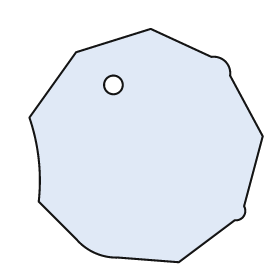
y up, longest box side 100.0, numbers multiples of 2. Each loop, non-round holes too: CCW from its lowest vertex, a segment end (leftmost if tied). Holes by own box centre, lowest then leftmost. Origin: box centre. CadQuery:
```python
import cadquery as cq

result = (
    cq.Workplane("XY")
    .moveTo(14.0, -50.0)
    .lineTo(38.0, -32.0)
    .threePointArc((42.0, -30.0), (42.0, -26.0))
    .lineTo(50.0, 4.0)
    .lineTo(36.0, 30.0)
    .threePointArc((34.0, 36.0), (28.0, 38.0))
    .lineTo(2.0, 50.0)
    .lineTo(-30.0, 40.0)
    .lineTo(-50.0, 12.0)
    .threePointArc((-46.0, -6.0), (-46.0, -24.0))
    .lineTo(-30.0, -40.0)
    .threePointArc((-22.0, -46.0), (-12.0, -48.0))
    .close()
    .moveTo(-14.0, 26.0)
    .circle(4.0)
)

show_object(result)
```